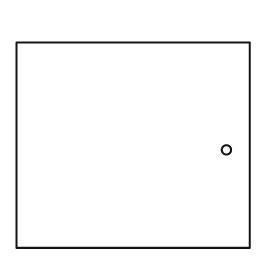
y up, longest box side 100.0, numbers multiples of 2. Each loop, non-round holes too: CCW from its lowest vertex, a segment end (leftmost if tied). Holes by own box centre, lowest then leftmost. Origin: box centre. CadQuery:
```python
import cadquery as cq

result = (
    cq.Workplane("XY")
    .moveTo(-50.0, -44.0)
    .lineTo(50.0, -44.0)
    .lineTo(50.0, 44.0)
    .lineTo(-50.0, 44.0)
    .close()
    .moveTo(40.0, -2.0)
    .circle(2.0)
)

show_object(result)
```